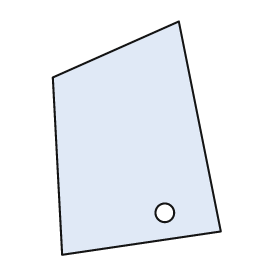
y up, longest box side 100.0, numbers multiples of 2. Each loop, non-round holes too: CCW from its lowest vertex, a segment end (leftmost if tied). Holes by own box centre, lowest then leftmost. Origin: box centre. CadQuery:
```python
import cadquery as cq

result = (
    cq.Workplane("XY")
    .moveTo(-32.0, -50.0)
    .lineTo(36.0, -40.0)
    .lineTo(18.0, 50.0)
    .lineTo(-36.0, 26.0)
    .close()
    .moveTo(12.0, -32.0)
    .circle(4.0)
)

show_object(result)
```